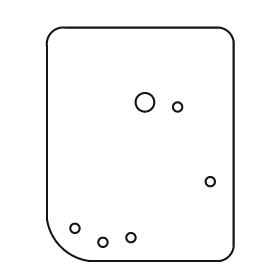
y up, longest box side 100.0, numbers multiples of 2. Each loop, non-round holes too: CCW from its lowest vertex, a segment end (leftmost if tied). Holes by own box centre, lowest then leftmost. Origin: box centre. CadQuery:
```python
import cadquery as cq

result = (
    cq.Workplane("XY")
    .moveTo(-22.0, -50.0)
    .lineTo(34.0, -50.0)
    .threePointArc((38.0, -48.0), (40.0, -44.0))
    .lineTo(40.0, 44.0)
    .threePointArc((38.0, 48.0), (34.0, 50.0))
    .lineTo(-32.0, 50.0)
    .threePointArc((-38.0, 48.0), (-40.0, 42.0))
    .lineTo(-40.0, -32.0)
    .threePointArc((-34.0, -44.0), (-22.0, -50.0))
    .close()
    .moveTo(-16.0, -42.0)
    .circle(2.0)
    .moveTo(-4.0, -40.0)
    .circle(2.0)
    .moveTo(-28.0, -36.0)
    .circle(2.0)
    .moveTo(30.0, -16.0)
    .circle(2.0)
    .moveTo(16.0, 16.0)
    .circle(2.0)
    .moveTo(2.0, 18.0)
    .circle(4.0)
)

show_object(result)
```